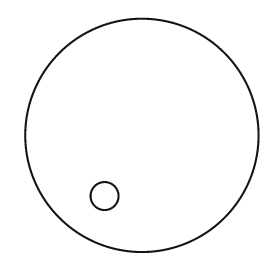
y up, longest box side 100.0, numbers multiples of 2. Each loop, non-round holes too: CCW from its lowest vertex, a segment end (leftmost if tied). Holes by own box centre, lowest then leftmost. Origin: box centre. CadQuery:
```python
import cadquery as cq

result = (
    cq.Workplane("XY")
    .moveTo(0.0, 0.0)
    .circle(50.0)
    .moveTo(-16.0, -26.0)
    .circle(6.0)
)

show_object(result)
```